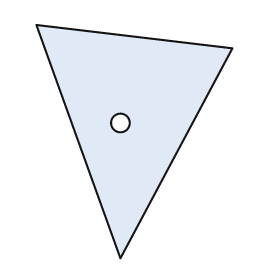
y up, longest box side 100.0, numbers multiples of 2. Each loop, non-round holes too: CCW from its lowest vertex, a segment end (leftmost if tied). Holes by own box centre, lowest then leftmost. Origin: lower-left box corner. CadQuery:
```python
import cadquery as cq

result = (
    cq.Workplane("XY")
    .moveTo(36.0, 0.0)
    .lineTo(84.0, 90.0)
    .lineTo(0.0, 100.0)
    .close()
    .moveTo(36.0, 58.0)
    .circle(4.0)
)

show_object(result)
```